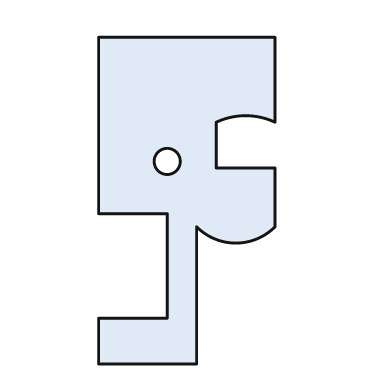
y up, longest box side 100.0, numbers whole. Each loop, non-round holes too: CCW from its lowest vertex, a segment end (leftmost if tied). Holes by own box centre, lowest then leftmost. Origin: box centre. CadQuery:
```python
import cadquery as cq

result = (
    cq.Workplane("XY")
    .moveTo(-27.0, -50.0)
    .lineTo(3.0, -50.0)
    .lineTo(3.0, -8.0)
    .threePointArc((15.0, -13.0), (27.0, -8.0))
    .lineTo(27.0, 10.0)
    .lineTo(9.0, 10.0)
    .lineTo(9.0, 24.0)
    .threePointArc((18.0, 26.0), (27.0, 24.0))
    .lineTo(27.0, 50.0)
    .lineTo(-27.0, 50.0)
    .lineTo(-27.0, -4.0)
    .lineTo(-6.0, -4.0)
    .lineTo(-6.0, -36.0)
    .lineTo(-27.0, -36.0)
    .close()
    .moveTo(-6.0, 12.0)
    .circle(4.0)
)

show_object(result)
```